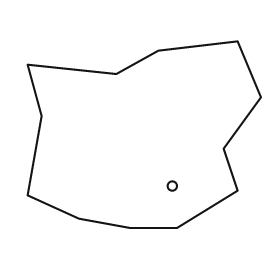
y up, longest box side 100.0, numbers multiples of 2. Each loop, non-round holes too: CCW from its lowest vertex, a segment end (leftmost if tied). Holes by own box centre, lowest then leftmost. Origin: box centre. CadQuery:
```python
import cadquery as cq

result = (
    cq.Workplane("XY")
    .moveTo(-6.0, -40.0)
    .lineTo(14.0, -40.0)
    .lineTo(40.0, -24.0)
    .lineTo(34.0, -6.0)
    .lineTo(50.0, 16.0)
    .lineTo(40.0, 40.0)
    .lineTo(6.0, 36.0)
    .lineTo(-12.0, 26.0)
    .lineTo(-50.0, 30.0)
    .lineTo(-44.0, 8.0)
    .lineTo(-50.0, -26.0)
    .lineTo(-28.0, -36.0)
    .close()
    .moveTo(12.0, -22.0)
    .circle(2.0)
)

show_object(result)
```